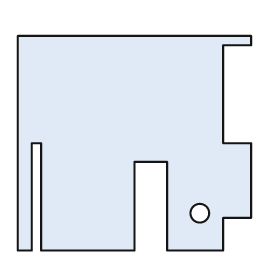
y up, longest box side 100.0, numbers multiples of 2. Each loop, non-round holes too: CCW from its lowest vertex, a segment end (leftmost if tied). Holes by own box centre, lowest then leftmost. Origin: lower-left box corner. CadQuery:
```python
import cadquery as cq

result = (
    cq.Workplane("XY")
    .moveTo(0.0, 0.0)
    .lineTo(6.0, 0.0)
    .lineTo(6.0, 46.0)
    .lineTo(10.0, 46.0)
    .lineTo(10.0, 0.0)
    .lineTo(50.0, 0.0)
    .lineTo(50.0, 38.0)
    .lineTo(64.0, 38.0)
    .lineTo(64.0, 0.0)
    .lineTo(88.0, 0.0)
    .lineTo(88.0, 14.0)
    .lineTo(100.0, 14.0)
    .lineTo(100.0, 46.0)
    .lineTo(88.0, 46.0)
    .lineTo(88.0, 88.0)
    .lineTo(100.0, 88.0)
    .lineTo(100.0, 92.0)
    .lineTo(0.0, 92.0)
    .close()
    .moveTo(78.0, 16.0)
    .circle(4.0)
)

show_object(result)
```